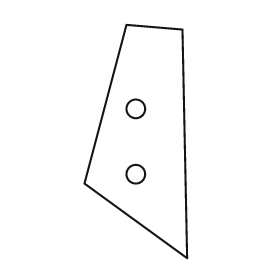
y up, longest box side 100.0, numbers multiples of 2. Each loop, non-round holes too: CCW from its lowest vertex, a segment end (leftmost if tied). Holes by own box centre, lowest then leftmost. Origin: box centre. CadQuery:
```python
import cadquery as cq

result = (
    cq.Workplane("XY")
    .moveTo(22.0, -50.0)
    .lineTo(20.0, 48.0)
    .lineTo(-4.0, 50.0)
    .lineTo(-22.0, -18.0)
    .close()
    .moveTo(0.0, -14.0)
    .circle(4.0)
    .moveTo(0.0, 14.0)
    .circle(4.0)
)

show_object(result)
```